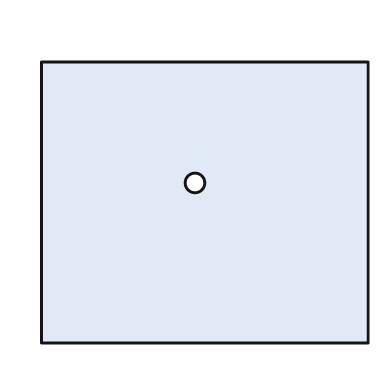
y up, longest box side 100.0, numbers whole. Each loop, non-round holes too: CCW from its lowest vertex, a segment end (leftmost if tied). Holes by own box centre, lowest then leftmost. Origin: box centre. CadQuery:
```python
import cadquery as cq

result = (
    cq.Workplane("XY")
    .moveTo(-50.0, -43.0)
    .lineTo(50.0, -43.0)
    .lineTo(50.0, 43.0)
    .lineTo(-50.0, 43.0)
    .close()
    .moveTo(-3.0, 6.0)
    .circle(3.0)
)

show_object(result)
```